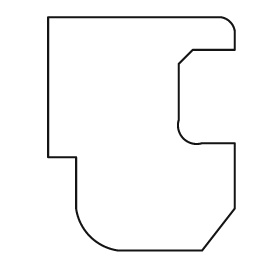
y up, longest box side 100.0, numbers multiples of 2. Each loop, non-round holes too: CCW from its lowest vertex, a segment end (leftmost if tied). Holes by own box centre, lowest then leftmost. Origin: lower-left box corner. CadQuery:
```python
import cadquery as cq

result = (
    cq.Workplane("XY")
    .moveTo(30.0, 0.0)
    .lineTo(66.0, 0.0)
    .lineTo(80.0, 18.0)
    .lineTo(80.0, 46.0)
    .lineTo(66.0, 46.0)
    .threePointArc((58.0, 48.0), (56.0, 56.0))
    .lineTo(56.0, 80.0)
    .lineTo(62.0, 86.0)
    .lineTo(80.0, 86.0)
    .lineTo(80.0, 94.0)
    .threePointArc((78.0, 98.0), (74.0, 100.0))
    .lineTo(0.0, 100.0)
    .lineTo(0.0, 40.0)
    .lineTo(12.0, 40.0)
    .lineTo(12.0, 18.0)
    .threePointArc((18.0, 6.0), (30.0, 0.0))
    .close()
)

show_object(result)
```